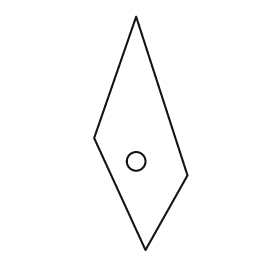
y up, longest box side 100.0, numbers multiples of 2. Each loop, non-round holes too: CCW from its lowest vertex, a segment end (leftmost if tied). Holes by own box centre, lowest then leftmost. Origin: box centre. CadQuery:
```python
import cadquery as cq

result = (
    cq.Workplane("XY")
    .moveTo(2.0, -50.0)
    .lineTo(20.0, -18.0)
    .lineTo(-2.0, 50.0)
    .lineTo(-20.0, -2.0)
    .close()
    .moveTo(-2.0, -12.0)
    .circle(4.0)
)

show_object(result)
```